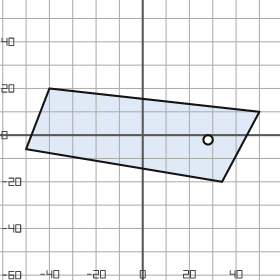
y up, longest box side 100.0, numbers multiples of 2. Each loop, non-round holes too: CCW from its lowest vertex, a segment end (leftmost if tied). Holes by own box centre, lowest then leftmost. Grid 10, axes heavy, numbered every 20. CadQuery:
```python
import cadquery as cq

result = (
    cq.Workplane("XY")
    .moveTo(34.0, -20.0)
    .lineTo(50.0, 10.0)
    .lineTo(-40.0, 20.0)
    .lineTo(-50.0, -6.0)
    .close()
    .moveTo(28.0, -2.0)
    .circle(2.0)
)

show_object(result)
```